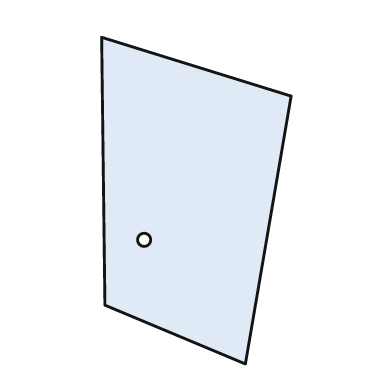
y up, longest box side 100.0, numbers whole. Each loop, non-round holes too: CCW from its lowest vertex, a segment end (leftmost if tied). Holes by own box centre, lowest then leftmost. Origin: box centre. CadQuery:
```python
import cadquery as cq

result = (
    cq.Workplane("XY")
    .moveTo(15.0, -50.0)
    .lineTo(29.0, 32.0)
    .lineTo(-29.0, 50.0)
    .lineTo(-28.0, -32.0)
    .close()
    .moveTo(-16.0, -12.0)
    .circle(2.0)
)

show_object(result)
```